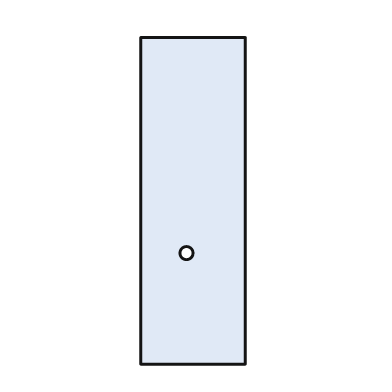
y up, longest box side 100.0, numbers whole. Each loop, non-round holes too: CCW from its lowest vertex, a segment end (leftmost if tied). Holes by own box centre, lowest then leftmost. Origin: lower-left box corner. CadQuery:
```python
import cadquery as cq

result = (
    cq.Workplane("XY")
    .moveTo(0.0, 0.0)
    .lineTo(32.0, 0.0)
    .lineTo(32.0, 100.0)
    .lineTo(0.0, 100.0)
    .close()
    .moveTo(14.0, 34.0)
    .circle(2.0)
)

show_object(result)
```